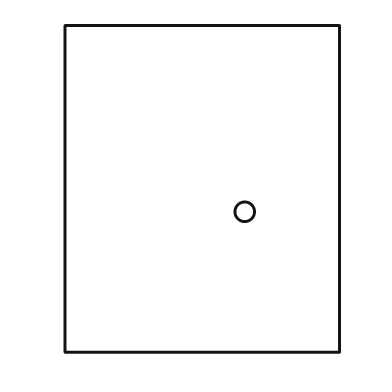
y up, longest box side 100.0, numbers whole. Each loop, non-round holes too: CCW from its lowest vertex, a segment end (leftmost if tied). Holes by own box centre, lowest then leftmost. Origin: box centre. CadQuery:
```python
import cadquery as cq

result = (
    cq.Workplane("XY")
    .moveTo(-42.0, -50.0)
    .lineTo(42.0, -50.0)
    .lineTo(42.0, 50.0)
    .lineTo(-42.0, 50.0)
    .close()
    .moveTo(13.0, -7.0)
    .circle(3.0)
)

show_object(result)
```